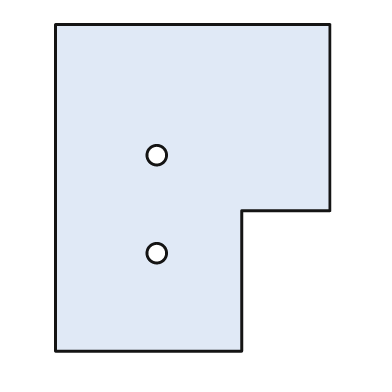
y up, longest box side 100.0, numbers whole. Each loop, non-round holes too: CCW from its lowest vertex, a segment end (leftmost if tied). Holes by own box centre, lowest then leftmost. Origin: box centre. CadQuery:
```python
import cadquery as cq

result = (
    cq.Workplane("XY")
    .moveTo(-42.0, -50.0)
    .lineTo(15.0, -50.0)
    .lineTo(15.0, -7.0)
    .lineTo(42.0, -7.0)
    .lineTo(42.0, 50.0)
    .lineTo(-42.0, 50.0)
    .close()
    .moveTo(-11.0, -20.0)
    .circle(3.0)
    .moveTo(-11.0, 10.0)
    .circle(3.0)
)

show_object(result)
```